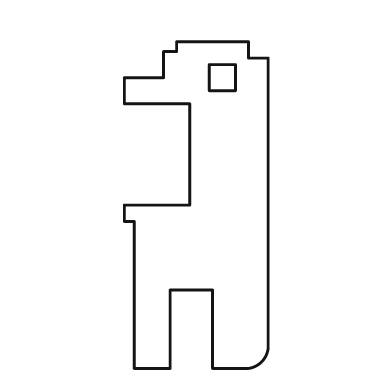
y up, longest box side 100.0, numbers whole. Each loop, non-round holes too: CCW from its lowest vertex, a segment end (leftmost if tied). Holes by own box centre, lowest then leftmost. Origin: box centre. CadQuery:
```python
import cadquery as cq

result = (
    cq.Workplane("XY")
    .moveTo(-19.0, -50.0)
    .lineTo(-8.0, -50.0)
    .lineTo(-8.0, -26.0)
    .lineTo(5.0, -26.0)
    .lineTo(5.0, -50.0)
    .lineTo(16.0, -50.0)
    .threePointArc((20.0, -48.0), (22.0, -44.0))
    .lineTo(22.0, 45.0)
    .lineTo(16.0, 45.0)
    .lineTo(16.0, 50.0)
    .lineTo(-6.0, 50.0)
    .lineTo(-6.0, 47.0)
    .lineTo(-10.0, 47.0)
    .lineTo(-10.0, 39.0)
    .lineTo(-22.0, 39.0)
    .lineTo(-22.0, 31.0)
    .lineTo(-2.0, 31.0)
    .lineTo(-2.0, 0.0)
    .lineTo(-22.0, 0.0)
    .lineTo(-22.0, -5.0)
    .lineTo(-19.0, -5.0)
    .close()
    .moveTo(4.0, 35.0)
    .lineTo(12.0, 35.0)
    .lineTo(12.0, 43.0)
    .lineTo(4.0, 43.0)
    .close()
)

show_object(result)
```